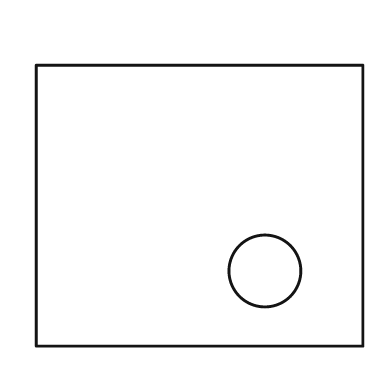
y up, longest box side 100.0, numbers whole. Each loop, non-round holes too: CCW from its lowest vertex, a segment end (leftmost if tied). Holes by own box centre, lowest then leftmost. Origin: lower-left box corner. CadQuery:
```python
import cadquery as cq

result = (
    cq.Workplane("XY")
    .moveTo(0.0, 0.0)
    .lineTo(100.0, 0.0)
    .lineTo(100.0, 86.0)
    .lineTo(0.0, 86.0)
    .close()
    .moveTo(70.0, 23.0)
    .circle(11.0)
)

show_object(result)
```